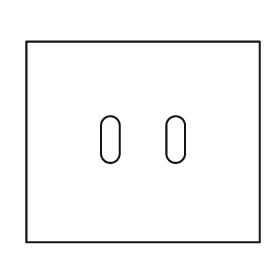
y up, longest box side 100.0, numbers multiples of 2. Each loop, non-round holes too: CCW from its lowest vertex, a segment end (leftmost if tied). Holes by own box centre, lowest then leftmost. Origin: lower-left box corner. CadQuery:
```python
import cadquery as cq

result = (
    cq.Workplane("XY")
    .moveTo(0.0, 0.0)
    .lineTo(100.0, 0.0)
    .lineTo(100.0, 86.0)
    .lineTo(0.0, 86.0)
    .close()
    .moveTo(32.0, 38.0)
    .threePointArc((36.0, 34.0), (40.0, 38.0))
    .lineTo(40.0, 50.0)
    .threePointArc((36.0, 54.0), (32.0, 50.0))
    .close()
    .moveTo(60.0, 38.0)
    .threePointArc((64.0, 34.0), (68.0, 38.0))
    .lineTo(68.0, 50.0)
    .threePointArc((64.0, 54.0), (60.0, 50.0))
    .close()
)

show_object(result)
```